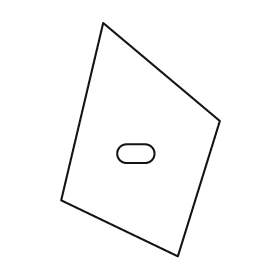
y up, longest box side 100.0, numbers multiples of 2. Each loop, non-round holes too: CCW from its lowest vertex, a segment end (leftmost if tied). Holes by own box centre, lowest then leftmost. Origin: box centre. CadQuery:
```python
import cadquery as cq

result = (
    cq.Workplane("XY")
    .moveTo(16.0, -50.0)
    .lineTo(34.0, 8.0)
    .lineTo(-16.0, 50.0)
    .lineTo(-34.0, -26.0)
    .close()
    .moveTo(-6.0, -10.0)
    .lineTo(2.0, -10.0)
    .threePointArc((6.0, -6.0), (2.0, -2.0))
    .lineTo(-6.0, -2.0)
    .threePointArc((-10.0, -6.0), (-6.0, -10.0))
    .close()
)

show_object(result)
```